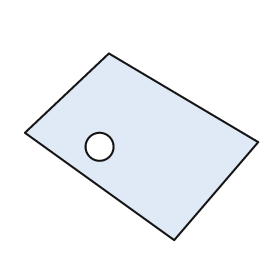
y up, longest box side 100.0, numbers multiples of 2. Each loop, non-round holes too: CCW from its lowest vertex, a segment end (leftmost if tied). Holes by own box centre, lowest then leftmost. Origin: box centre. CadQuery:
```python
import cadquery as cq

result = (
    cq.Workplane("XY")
    .moveTo(14.0, -40.0)
    .lineTo(50.0, 2.0)
    .lineTo(-14.0, 40.0)
    .lineTo(-50.0, 6.0)
    .close()
    .moveTo(-18.0, 0.0)
    .circle(6.0)
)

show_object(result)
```